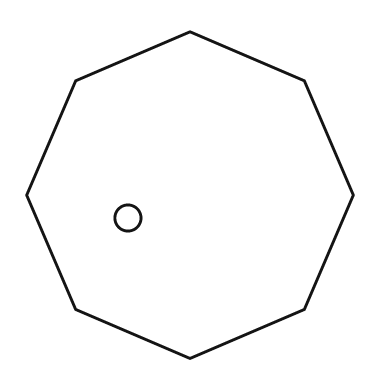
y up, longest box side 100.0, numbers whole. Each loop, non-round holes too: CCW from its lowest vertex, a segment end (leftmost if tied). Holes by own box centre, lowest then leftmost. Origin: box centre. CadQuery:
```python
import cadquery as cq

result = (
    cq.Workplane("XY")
    .moveTo(0.0, -50.0)
    .lineTo(35.0, -35.0)
    .lineTo(50.0, 0.0)
    .lineTo(35.0, 35.0)
    .lineTo(0.0, 50.0)
    .lineTo(-35.0, 35.0)
    .lineTo(-50.0, 0.0)
    .lineTo(-35.0, -35.0)
    .close()
    .moveTo(-19.0, -7.0)
    .circle(4.0)
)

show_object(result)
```